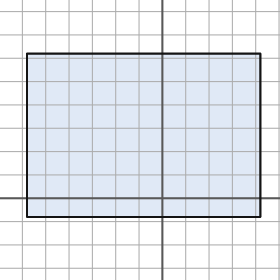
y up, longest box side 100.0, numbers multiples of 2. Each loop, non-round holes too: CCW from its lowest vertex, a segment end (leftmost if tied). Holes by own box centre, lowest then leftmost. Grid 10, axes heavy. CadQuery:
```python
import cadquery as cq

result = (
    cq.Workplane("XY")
    .moveTo(-58.0, -8.0)
    .lineTo(42.0, -8.0)
    .lineTo(42.0, 62.0)
    .lineTo(-58.0, 62.0)
    .close()
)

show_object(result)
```